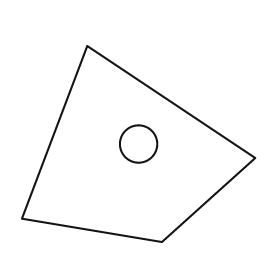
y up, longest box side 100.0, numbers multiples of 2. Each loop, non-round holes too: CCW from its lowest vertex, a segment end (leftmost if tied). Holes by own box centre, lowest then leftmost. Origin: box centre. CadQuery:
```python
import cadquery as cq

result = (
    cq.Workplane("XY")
    .moveTo(10.0, -42.0)
    .lineTo(50.0, -6.0)
    .lineTo(-22.0, 42.0)
    .lineTo(-50.0, -32.0)
    .close()
    .moveTo(0.0, 0.0)
    .circle(8.0)
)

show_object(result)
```